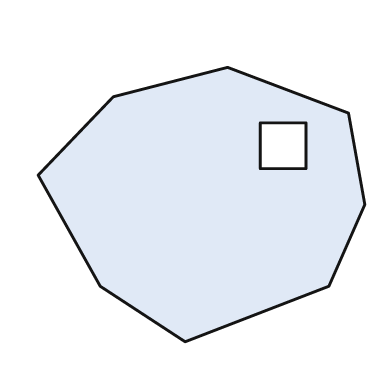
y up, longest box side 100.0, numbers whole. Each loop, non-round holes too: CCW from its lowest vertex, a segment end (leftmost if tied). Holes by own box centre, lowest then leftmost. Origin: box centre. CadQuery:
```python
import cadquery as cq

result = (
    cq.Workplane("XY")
    .moveTo(-5.0, -42.0)
    .lineTo(39.0, -25.0)
    .lineTo(50.0, 0.0)
    .lineTo(45.0, 28.0)
    .lineTo(8.0, 42.0)
    .lineTo(-27.0, 33.0)
    .lineTo(-50.0, 9.0)
    .lineTo(-31.0, -25.0)
    .close()
    .moveTo(18.0, 11.0)
    .lineTo(32.0, 11.0)
    .lineTo(32.0, 25.0)
    .lineTo(18.0, 25.0)
    .close()
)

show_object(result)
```